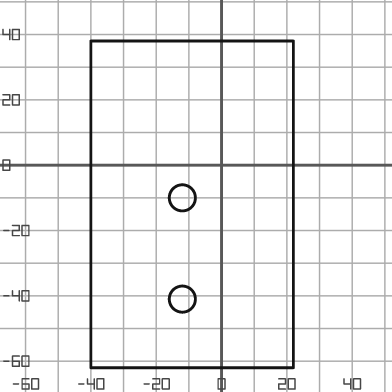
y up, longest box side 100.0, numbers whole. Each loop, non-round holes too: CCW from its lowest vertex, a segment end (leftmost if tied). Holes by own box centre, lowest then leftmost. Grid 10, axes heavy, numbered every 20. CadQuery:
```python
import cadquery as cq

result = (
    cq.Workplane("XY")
    .moveTo(-40.0, -62.0)
    .lineTo(22.0, -62.0)
    .lineTo(22.0, 38.0)
    .lineTo(-40.0, 38.0)
    .close()
    .moveTo(-12.0, -41.0)
    .circle(4.0)
    .moveTo(-12.0, -10.0)
    .circle(4.0)
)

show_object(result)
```